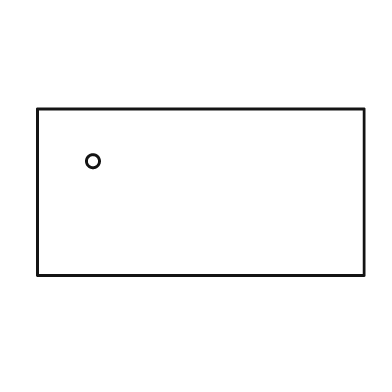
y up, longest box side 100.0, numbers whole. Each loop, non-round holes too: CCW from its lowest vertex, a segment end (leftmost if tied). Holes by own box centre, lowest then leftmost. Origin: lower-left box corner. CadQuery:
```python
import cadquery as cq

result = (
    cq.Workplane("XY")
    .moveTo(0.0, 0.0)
    .lineTo(100.0, 0.0)
    .lineTo(100.0, 51.0)
    .lineTo(0.0, 51.0)
    .close()
    .moveTo(17.0, 35.0)
    .circle(2.0)
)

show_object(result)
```